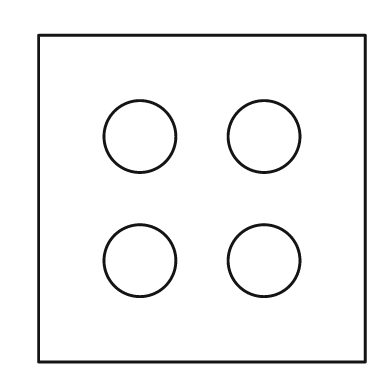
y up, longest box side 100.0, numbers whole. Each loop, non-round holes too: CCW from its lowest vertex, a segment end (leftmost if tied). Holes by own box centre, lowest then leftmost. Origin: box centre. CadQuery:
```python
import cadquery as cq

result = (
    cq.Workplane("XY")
    .moveTo(-50.0, -50.0)
    .lineTo(50.0, -50.0)
    .lineTo(50.0, 50.0)
    .lineTo(-50.0, 50.0)
    .close()
    .moveTo(-19.0, -19.0)
    .circle(11.0)
    .moveTo(19.0, -19.0)
    .circle(11.0)
    .moveTo(-19.0, 19.0)
    .circle(11.0)
    .moveTo(19.0, 19.0)
    .circle(11.0)
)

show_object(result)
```